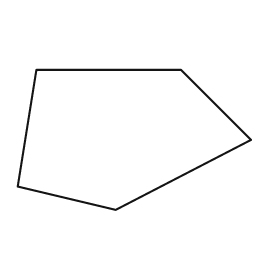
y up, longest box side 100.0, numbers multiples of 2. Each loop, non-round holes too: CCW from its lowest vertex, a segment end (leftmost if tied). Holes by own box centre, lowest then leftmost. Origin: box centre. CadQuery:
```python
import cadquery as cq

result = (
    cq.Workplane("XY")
    .moveTo(-8.0, -30.0)
    .lineTo(50.0, 0.0)
    .lineTo(20.0, 30.0)
    .lineTo(-42.0, 30.0)
    .lineTo(-50.0, -20.0)
    .close()
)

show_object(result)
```